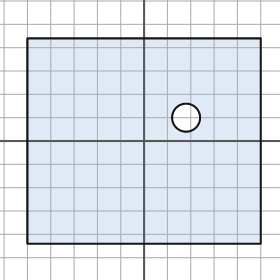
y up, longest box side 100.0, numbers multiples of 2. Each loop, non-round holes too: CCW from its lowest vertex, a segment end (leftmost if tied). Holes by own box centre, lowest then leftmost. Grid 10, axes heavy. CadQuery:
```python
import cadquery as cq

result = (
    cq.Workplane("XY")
    .moveTo(-50.0, -44.0)
    .lineTo(50.0, -44.0)
    .lineTo(50.0, 44.0)
    .lineTo(-50.0, 44.0)
    .close()
    .moveTo(18.0, 10.0)
    .circle(6.0)
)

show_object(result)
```